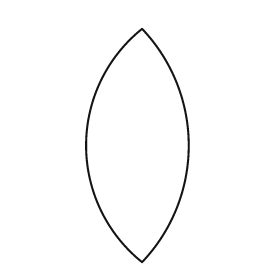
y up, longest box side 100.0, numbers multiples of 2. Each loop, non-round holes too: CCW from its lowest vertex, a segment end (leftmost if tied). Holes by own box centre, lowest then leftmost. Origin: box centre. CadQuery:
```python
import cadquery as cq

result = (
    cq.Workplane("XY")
    .moveTo(2.0, -50.0)
    .threePointArc((22.0, 0.0), (2.0, 50.0))
    .threePointArc((-22.0, 0.0), (2.0, -50.0))
    .close()
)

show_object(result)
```